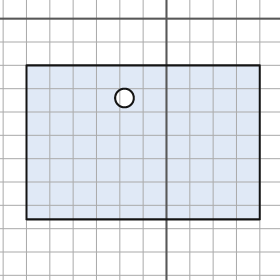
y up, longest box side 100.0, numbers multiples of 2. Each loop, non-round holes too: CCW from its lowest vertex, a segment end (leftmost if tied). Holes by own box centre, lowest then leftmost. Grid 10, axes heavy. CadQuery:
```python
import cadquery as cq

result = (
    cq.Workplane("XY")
    .moveTo(-60.0, -86.0)
    .lineTo(40.0, -86.0)
    .lineTo(40.0, -20.0)
    .lineTo(-60.0, -20.0)
    .close()
    .moveTo(-18.0, -34.0)
    .circle(4.0)
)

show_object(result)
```